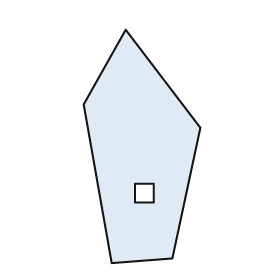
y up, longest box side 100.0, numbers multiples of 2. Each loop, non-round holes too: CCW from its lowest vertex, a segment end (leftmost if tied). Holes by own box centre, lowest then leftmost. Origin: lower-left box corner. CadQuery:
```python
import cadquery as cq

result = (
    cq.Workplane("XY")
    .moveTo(12.0, 0.0)
    .lineTo(38.0, 2.0)
    .lineTo(50.0, 58.0)
    .lineTo(18.0, 100.0)
    .lineTo(0.0, 68.0)
    .close()
    .moveTo(22.0, 26.0)
    .lineTo(30.0, 26.0)
    .lineTo(30.0, 34.0)
    .lineTo(22.0, 34.0)
    .close()
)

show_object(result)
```